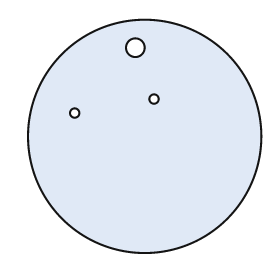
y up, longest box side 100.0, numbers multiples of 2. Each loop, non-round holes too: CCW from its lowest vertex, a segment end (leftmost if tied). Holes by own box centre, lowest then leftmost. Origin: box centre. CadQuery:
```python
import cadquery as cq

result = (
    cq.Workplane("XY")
    .moveTo(0.0, 0.0)
    .circle(50.0)
    .moveTo(-30.0, 10.0)
    .circle(2.0)
    .moveTo(4.0, 16.0)
    .circle(2.0)
    .moveTo(-4.0, 38.0)
    .circle(4.0)
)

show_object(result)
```